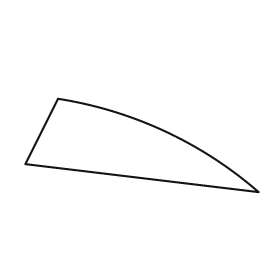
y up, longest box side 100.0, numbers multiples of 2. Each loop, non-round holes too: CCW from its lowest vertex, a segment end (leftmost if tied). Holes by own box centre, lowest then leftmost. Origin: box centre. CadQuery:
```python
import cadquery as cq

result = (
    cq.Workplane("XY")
    .moveTo(50.0, -20.0)
    .threePointArc((10.0, 6.0), (-36.0, 20.0))
    .lineTo(-50.0, -8.0)
    .close()
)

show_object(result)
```